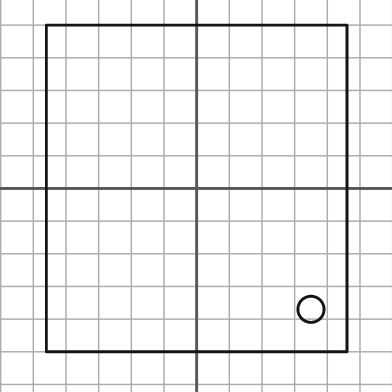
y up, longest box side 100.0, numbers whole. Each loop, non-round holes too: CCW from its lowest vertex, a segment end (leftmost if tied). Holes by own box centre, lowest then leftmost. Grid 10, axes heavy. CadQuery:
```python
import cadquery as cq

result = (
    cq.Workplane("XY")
    .moveTo(-46.0, -50.0)
    .lineTo(46.0, -50.0)
    .lineTo(46.0, 50.0)
    .lineTo(-46.0, 50.0)
    .close()
    .moveTo(35.0, -37.0)
    .circle(4.0)
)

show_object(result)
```